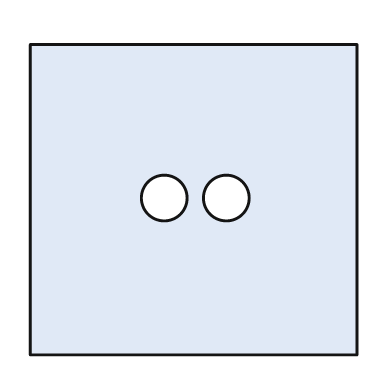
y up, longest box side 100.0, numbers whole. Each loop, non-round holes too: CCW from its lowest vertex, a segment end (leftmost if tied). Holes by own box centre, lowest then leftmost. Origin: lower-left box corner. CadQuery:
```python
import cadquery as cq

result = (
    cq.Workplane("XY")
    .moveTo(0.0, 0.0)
    .lineTo(100.0, 0.0)
    .lineTo(100.0, 95.0)
    .lineTo(0.0, 95.0)
    .close()
    .moveTo(41.0, 48.0)
    .circle(7.0)
    .moveTo(60.0, 48.0)
    .circle(7.0)
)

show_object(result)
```